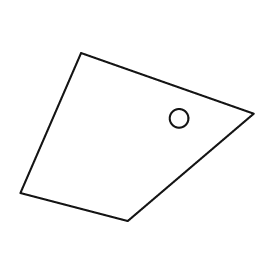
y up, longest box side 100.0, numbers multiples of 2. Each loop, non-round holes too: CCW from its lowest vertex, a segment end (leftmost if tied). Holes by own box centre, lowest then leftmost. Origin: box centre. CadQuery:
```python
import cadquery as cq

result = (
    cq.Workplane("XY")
    .moveTo(-4.0, -36.0)
    .lineTo(50.0, 10.0)
    .lineTo(-24.0, 36.0)
    .lineTo(-50.0, -24.0)
    .close()
    .moveTo(18.0, 8.0)
    .circle(4.0)
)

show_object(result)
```